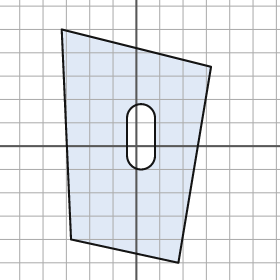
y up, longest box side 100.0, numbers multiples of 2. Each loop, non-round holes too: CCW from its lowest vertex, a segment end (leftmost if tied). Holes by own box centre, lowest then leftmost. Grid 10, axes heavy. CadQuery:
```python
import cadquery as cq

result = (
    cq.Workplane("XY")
    .moveTo(18.0, -50.0)
    .lineTo(32.0, 34.0)
    .lineTo(-32.0, 50.0)
    .lineTo(-28.0, -40.0)
    .close()
    .moveTo(-4.0, -4.0)
    .threePointArc((2.0, -10.0), (8.0, -4.0))
    .lineTo(8.0, 12.0)
    .threePointArc((2.0, 18.0), (-4.0, 12.0))
    .close()
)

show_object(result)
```